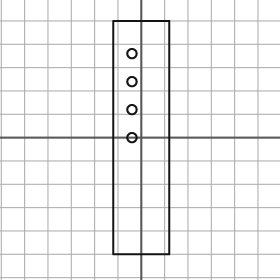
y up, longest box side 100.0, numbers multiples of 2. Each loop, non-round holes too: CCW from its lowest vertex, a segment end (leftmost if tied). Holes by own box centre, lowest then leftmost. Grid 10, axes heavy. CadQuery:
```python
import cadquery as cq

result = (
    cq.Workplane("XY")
    .moveTo(-12.0, -50.0)
    .lineTo(12.0, -50.0)
    .lineTo(12.0, 50.0)
    .lineTo(-12.0, 50.0)
    .close()
    .moveTo(-4.0, 0.0)
    .circle(2.0)
    .moveTo(-4.0, 12.0)
    .circle(2.0)
    .moveTo(-4.0, 24.0)
    .circle(2.0)
    .moveTo(-4.0, 36.0)
    .circle(2.0)
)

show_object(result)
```